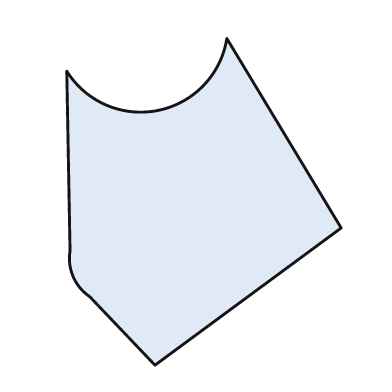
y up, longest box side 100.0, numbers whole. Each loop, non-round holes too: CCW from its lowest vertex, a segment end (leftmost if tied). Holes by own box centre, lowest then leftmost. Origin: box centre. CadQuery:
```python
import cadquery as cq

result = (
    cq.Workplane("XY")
    .moveTo(-15.0, -50.0)
    .lineTo(42.0, -8.0)
    .lineTo(7.0, 50.0)
    .threePointArc((-14.0, 28.0), (-42.0, 40.0))
    .lineTo(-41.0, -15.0)
    .threePointArc((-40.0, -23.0), (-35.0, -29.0))
    .close()
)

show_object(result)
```